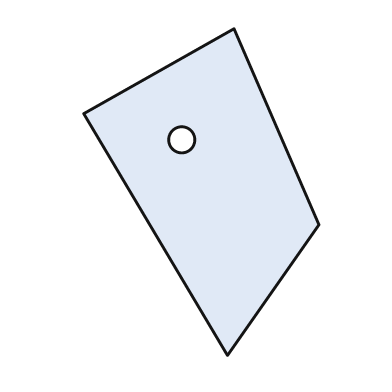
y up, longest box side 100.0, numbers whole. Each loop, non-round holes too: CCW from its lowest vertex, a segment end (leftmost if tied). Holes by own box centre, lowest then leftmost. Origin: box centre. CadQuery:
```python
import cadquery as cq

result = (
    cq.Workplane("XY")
    .moveTo(8.0, -50.0)
    .lineTo(36.0, -10.0)
    .lineTo(10.0, 50.0)
    .lineTo(-36.0, 24.0)
    .close()
    .moveTo(-6.0, 16.0)
    .circle(4.0)
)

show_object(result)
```